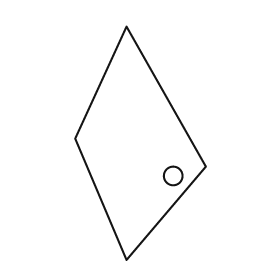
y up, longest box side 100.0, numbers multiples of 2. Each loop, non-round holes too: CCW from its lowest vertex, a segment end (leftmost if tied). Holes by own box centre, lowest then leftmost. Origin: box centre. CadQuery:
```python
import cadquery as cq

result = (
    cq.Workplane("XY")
    .moveTo(-6.0, -50.0)
    .lineTo(28.0, -10.0)
    .lineTo(-6.0, 50.0)
    .lineTo(-28.0, 2.0)
    .close()
    .moveTo(14.0, -14.0)
    .circle(4.0)
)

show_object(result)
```